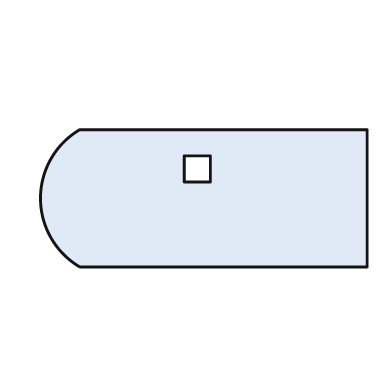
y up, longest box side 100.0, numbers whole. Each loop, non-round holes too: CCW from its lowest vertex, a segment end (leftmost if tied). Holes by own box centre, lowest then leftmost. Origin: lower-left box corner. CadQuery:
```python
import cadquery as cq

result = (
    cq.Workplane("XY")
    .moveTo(12.0, 0.0)
    .lineTo(100.0, 0.0)
    .lineTo(100.0, 42.0)
    .lineTo(12.0, 42.0)
    .threePointArc((0.0, 21.0), (12.0, 0.0))
    .close()
    .moveTo(44.0, 26.0)
    .lineTo(52.0, 26.0)
    .lineTo(52.0, 34.0)
    .lineTo(44.0, 34.0)
    .close()
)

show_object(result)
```